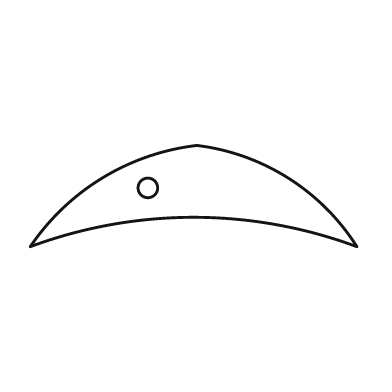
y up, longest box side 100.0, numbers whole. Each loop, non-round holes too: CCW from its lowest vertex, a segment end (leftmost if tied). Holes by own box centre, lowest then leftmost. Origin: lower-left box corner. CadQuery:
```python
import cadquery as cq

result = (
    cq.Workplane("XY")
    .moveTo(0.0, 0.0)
    .threePointArc((50.0, 9.0), (100.0, 0.0))
    .threePointArc((79.0, 21.0), (51.0, 31.0))
    .threePointArc((22.0, 21.0), (0.0, 0.0))
    .close()
    .moveTo(36.0, 18.0)
    .circle(3.0)
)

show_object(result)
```